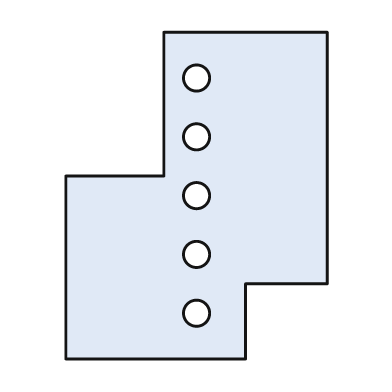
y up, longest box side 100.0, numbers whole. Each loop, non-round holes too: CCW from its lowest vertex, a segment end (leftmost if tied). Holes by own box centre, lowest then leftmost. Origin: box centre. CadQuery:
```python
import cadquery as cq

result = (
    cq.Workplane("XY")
    .moveTo(-40.0, -50.0)
    .lineTo(15.0, -50.0)
    .lineTo(15.0, -27.0)
    .lineTo(40.0, -27.0)
    .lineTo(40.0, 50.0)
    .lineTo(-10.0, 50.0)
    .lineTo(-10.0, 6.0)
    .lineTo(-40.0, 6.0)
    .close()
    .moveTo(0.0, -36.0)
    .circle(4.0)
    .moveTo(0.0, -18.0)
    .circle(4.0)
    .moveTo(0.0, 0.0)
    .circle(4.0)
    .moveTo(0.0, 18.0)
    .circle(4.0)
    .moveTo(0.0, 36.0)
    .circle(4.0)
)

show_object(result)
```